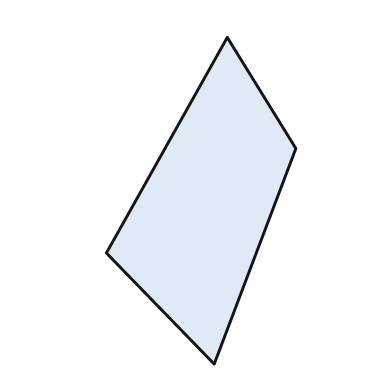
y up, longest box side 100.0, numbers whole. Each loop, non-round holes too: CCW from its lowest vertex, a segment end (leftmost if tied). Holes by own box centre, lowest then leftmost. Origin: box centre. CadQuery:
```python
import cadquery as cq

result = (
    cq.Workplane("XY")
    .moveTo(4.0, -50.0)
    .lineTo(29.0, 16.0)
    .lineTo(8.0, 50.0)
    .lineTo(-29.0, -16.0)
    .close()
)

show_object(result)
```